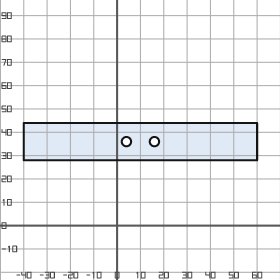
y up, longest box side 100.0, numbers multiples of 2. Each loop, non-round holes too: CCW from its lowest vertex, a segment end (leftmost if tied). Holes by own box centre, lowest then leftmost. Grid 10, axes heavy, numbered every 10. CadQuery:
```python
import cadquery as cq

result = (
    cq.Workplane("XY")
    .moveTo(-40.0, 28.0)
    .lineTo(60.0, 28.0)
    .lineTo(60.0, 44.0)
    .lineTo(-40.0, 44.0)
    .close()
    .moveTo(4.0, 36.0)
    .circle(2.0)
    .moveTo(16.0, 36.0)
    .circle(2.0)
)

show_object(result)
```